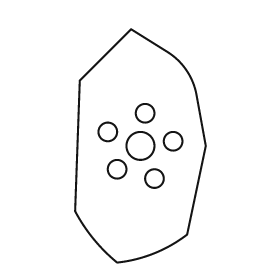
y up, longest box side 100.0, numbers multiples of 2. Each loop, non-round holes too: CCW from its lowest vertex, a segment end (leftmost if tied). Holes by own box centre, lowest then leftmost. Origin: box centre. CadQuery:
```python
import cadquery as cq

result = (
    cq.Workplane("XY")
    .moveTo(-10.0, -50.0)
    .threePointArc((6.0, -46.0), (20.0, -38.0))
    .lineTo(28.0, 0.0)
    .lineTo(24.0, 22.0)
    .threePointArc((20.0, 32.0), (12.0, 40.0))
    .lineTo(-4.0, 50.0)
    .lineTo(-26.0, 28.0)
    .lineTo(-28.0, -28.0)
    .threePointArc((-20.0, -40.0), (-10.0, -50.0))
    .close()
    .moveTo(6.0, -14.0)
    .circle(4.0)
    .moveTo(-10.0, -10.0)
    .circle(4.0)
    .moveTo(0.0, 0.0)
    .circle(6.0)
    .moveTo(14.0, 2.0)
    .circle(4.0)
    .moveTo(-14.0, 6.0)
    .circle(4.0)
    .moveTo(2.0, 14.0)
    .circle(4.0)
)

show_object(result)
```